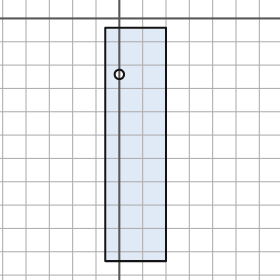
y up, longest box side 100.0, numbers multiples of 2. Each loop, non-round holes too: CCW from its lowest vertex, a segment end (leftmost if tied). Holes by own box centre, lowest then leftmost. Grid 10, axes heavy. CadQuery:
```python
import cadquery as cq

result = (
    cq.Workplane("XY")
    .moveTo(-6.0, -104.0)
    .lineTo(20.0, -104.0)
    .lineTo(20.0, -4.0)
    .lineTo(-6.0, -4.0)
    .close()
    .moveTo(0.0, -24.0)
    .circle(2.0)
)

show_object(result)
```